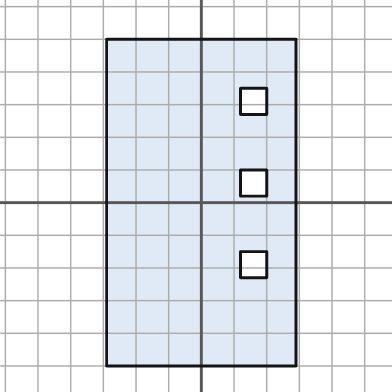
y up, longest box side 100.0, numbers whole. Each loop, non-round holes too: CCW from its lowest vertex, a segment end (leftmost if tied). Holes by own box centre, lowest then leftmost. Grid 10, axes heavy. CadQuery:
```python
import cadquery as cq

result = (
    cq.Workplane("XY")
    .moveTo(-29.0, -50.0)
    .lineTo(29.0, -50.0)
    .lineTo(29.0, 50.0)
    .lineTo(-29.0, 50.0)
    .close()
    .moveTo(12.0, -23.0)
    .lineTo(20.0, -23.0)
    .lineTo(20.0, -15.0)
    .lineTo(12.0, -15.0)
    .close()
    .moveTo(12.0, 2.0)
    .lineTo(20.0, 2.0)
    .lineTo(20.0, 10.0)
    .lineTo(12.0, 10.0)
    .close()
    .moveTo(12.0, 27.0)
    .lineTo(20.0, 27.0)
    .lineTo(20.0, 35.0)
    .lineTo(12.0, 35.0)
    .close()
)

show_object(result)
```